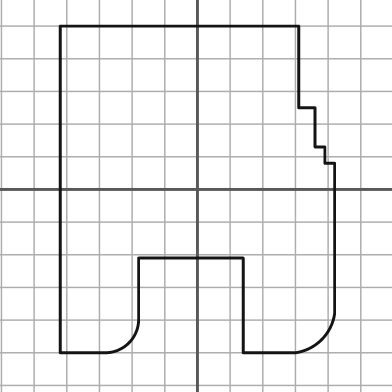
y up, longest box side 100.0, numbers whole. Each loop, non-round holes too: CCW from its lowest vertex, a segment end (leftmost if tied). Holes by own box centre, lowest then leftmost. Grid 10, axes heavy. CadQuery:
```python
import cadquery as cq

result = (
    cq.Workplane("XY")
    .moveTo(-42.0, -50.0)
    .lineTo(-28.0, -50.0)
    .threePointArc((-21.0, -47.0), (-18.0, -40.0))
    .lineTo(-18.0, -21.0)
    .lineTo(14.0, -21.0)
    .lineTo(14.0, -50.0)
    .lineTo(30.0, -50.0)
    .threePointArc((38.0, -46.0), (42.0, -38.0))
    .lineTo(42.0, 8.0)
    .lineTo(39.0, 8.0)
    .lineTo(39.0, 13.0)
    .lineTo(36.0, 13.0)
    .lineTo(36.0, 25.0)
    .lineTo(31.0, 25.0)
    .lineTo(31.0, 50.0)
    .lineTo(-42.0, 50.0)
    .close()
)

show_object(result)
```